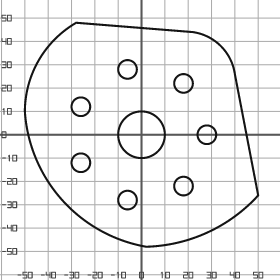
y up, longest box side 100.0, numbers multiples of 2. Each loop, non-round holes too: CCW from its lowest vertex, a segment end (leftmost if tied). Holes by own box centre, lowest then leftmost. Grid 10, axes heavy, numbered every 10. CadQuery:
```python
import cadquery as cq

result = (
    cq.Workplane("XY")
    .moveTo(2.0, -48.0)
    .threePointArc((28.0, -42.0), (50.0, -26.0))
    .lineTo(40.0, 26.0)
    .threePointArc((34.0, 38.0), (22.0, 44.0))
    .lineTo(-28.0, 48.0)
    .threePointArc((-44.0, 32.0), (-50.0, 10.0))
    .threePointArc((-34.0, -28.0), (2.0, -48.0))
    .close()
    .moveTo(-6.0, -28.0)
    .circle(4.0)
    .moveTo(18.0, -22.0)
    .circle(4.0)
    .moveTo(-26.0, -12.0)
    .circle(4.0)
    .moveTo(0.0, 0.0)
    .circle(10.0)
    .moveTo(28.0, 0.0)
    .circle(4.0)
    .moveTo(-26.0, 12.0)
    .circle(4.0)
    .moveTo(18.0, 22.0)
    .circle(4.0)
    .moveTo(-6.0, 28.0)
    .circle(4.0)
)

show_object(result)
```